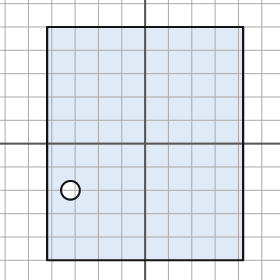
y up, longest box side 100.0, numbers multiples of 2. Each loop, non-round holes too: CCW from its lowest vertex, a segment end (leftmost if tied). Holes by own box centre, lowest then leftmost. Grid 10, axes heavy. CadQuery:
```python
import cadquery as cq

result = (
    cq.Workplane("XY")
    .moveTo(-42.0, -50.0)
    .lineTo(42.0, -50.0)
    .lineTo(42.0, 50.0)
    .lineTo(-42.0, 50.0)
    .close()
    .moveTo(-32.0, -20.0)
    .circle(4.0)
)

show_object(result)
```